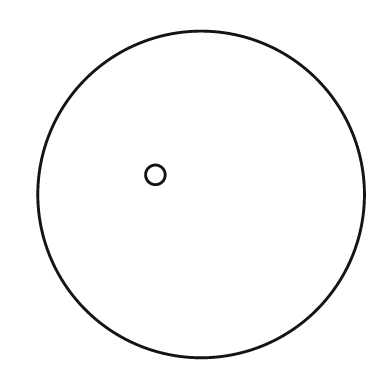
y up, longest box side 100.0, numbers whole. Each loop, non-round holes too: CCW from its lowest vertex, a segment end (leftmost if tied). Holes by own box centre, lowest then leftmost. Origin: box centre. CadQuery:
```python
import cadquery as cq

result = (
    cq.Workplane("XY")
    .moveTo(0.0, 0.0)
    .circle(50.0)
    .moveTo(-14.0, 6.0)
    .circle(3.0)
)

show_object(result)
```